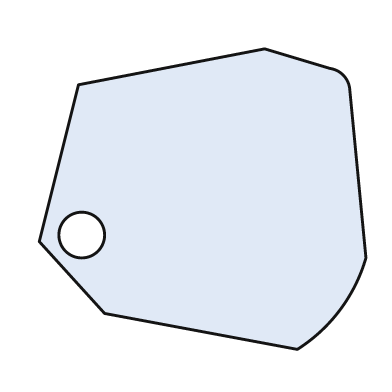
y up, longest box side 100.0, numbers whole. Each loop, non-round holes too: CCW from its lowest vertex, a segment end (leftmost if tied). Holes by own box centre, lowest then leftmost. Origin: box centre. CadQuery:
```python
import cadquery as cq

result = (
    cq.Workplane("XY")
    .moveTo(29.0, -46.0)
    .threePointArc((42.0, -34.0), (50.0, -18.0))
    .lineTo(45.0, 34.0)
    .threePointArc((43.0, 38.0), (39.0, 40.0))
    .lineTo(19.0, 46.0)
    .lineTo(-38.0, 35.0)
    .lineTo(-50.0, -13.0)
    .lineTo(-30.0, -35.0)
    .close()
    .moveTo(-37.0, -11.0)
    .circle(7.0)
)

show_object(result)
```